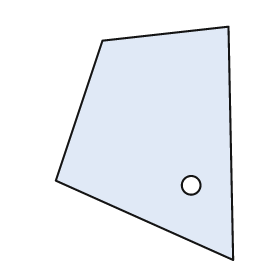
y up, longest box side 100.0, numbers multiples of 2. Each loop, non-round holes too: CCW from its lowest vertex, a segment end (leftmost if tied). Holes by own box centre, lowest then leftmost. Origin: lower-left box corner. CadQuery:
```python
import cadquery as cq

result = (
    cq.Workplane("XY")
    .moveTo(76.0, 0.0)
    .lineTo(74.0, 100.0)
    .lineTo(20.0, 94.0)
    .lineTo(0.0, 34.0)
    .close()
    .moveTo(58.0, 32.0)
    .circle(4.0)
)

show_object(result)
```